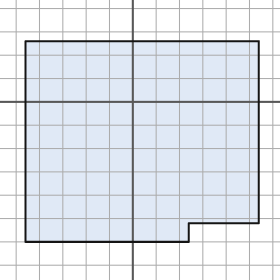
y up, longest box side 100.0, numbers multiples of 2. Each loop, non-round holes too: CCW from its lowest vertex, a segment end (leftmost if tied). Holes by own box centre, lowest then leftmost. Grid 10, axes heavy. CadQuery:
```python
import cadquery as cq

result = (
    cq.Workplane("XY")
    .moveTo(-46.0, -60.0)
    .lineTo(24.0, -60.0)
    .lineTo(24.0, -52.0)
    .lineTo(54.0, -52.0)
    .lineTo(54.0, 26.0)
    .lineTo(-46.0, 26.0)
    .close()
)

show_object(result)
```